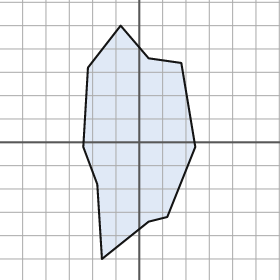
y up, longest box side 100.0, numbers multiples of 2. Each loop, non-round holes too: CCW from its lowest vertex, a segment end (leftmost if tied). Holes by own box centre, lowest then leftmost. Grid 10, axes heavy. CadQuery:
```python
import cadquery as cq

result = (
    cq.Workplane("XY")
    .moveTo(-16.0, -50.0)
    .lineTo(4.0, -34.0)
    .lineTo(12.0, -32.0)
    .lineTo(24.0, -2.0)
    .lineTo(18.0, 34.0)
    .lineTo(4.0, 36.0)
    .lineTo(-8.0, 50.0)
    .lineTo(-22.0, 32.0)
    .lineTo(-24.0, -2.0)
    .lineTo(-18.0, -18.0)
    .close()
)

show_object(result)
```